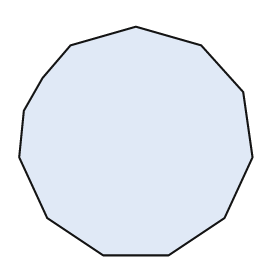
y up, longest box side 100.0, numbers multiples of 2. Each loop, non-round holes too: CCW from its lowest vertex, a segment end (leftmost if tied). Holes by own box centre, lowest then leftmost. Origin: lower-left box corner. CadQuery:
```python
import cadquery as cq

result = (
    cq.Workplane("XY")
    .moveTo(36.0, 0.0)
    .lineTo(64.0, 0.0)
    .lineTo(88.0, 16.0)
    .lineTo(100.0, 42.0)
    .lineTo(96.0, 70.0)
    .lineTo(78.0, 90.0)
    .lineTo(50.0, 98.0)
    .lineTo(22.0, 90.0)
    .lineTo(10.0, 76.0)
    .lineTo(2.0, 62.0)
    .lineTo(0.0, 42.0)
    .lineTo(12.0, 16.0)
    .close()
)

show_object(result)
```